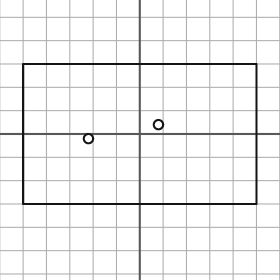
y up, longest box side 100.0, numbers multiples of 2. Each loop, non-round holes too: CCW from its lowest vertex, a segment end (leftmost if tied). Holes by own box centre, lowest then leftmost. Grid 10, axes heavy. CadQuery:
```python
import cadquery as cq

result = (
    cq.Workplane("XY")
    .moveTo(-50.0, -30.0)
    .lineTo(50.0, -30.0)
    .lineTo(50.0, 30.0)
    .lineTo(-50.0, 30.0)
    .close()
    .moveTo(-22.0, -2.0)
    .circle(2.0)
    .moveTo(8.0, 4.0)
    .circle(2.0)
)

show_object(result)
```